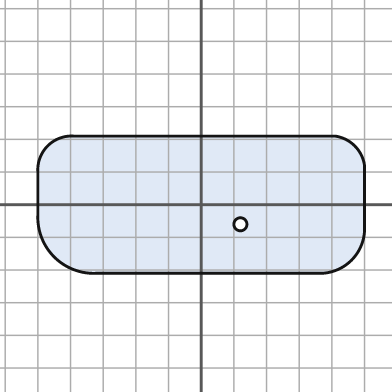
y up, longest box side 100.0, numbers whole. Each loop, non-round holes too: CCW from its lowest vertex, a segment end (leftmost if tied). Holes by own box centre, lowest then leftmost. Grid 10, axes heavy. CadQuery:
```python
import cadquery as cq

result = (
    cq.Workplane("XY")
    .moveTo(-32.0, -21.0)
    .lineTo(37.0, -21.0)
    .threePointArc((46.0, -17.0), (50.0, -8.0))
    .lineTo(50.0, 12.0)
    .threePointArc((47.0, 18.0), (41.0, 21.0))
    .lineTo(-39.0, 21.0)
    .threePointArc((-47.0, 18.0), (-50.0, 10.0))
    .lineTo(-50.0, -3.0)
    .threePointArc((-45.0, -16.0), (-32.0, -21.0))
    .close()
    .moveTo(12.0, -6.0)
    .circle(2.0)
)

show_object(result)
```